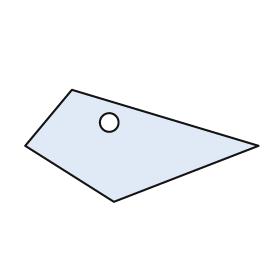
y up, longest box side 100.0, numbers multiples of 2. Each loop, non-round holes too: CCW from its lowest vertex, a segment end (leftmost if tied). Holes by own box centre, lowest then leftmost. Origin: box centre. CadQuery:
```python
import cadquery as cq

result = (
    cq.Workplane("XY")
    .moveTo(-12.0, -24.0)
    .lineTo(50.0, 0.0)
    .lineTo(-30.0, 24.0)
    .lineTo(-50.0, 0.0)
    .close()
    .moveTo(-14.0, 10.0)
    .circle(4.0)
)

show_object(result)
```